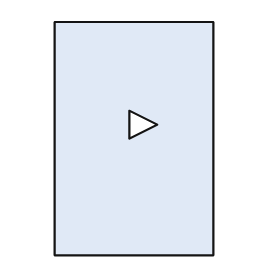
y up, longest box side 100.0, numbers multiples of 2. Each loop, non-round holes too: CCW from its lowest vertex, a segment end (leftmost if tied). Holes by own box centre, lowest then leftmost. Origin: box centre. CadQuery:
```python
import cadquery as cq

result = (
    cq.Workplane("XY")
    .moveTo(-34.0, -50.0)
    .lineTo(34.0, -50.0)
    .lineTo(34.0, 50.0)
    .lineTo(-34.0, 50.0)
    .close()
    .moveTo(-2.0, 0.0)
    .lineTo(10.0, 6.0)
    .lineTo(-2.0, 12.0)
    .close()
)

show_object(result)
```